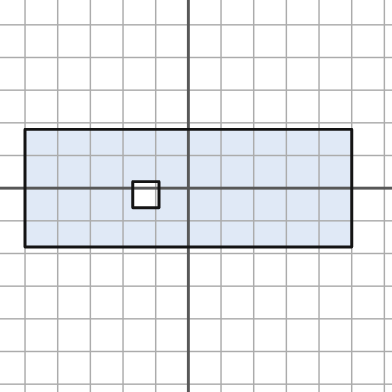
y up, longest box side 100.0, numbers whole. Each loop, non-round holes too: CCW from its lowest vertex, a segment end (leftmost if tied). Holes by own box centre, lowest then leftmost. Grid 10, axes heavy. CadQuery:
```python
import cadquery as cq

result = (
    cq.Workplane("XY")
    .moveTo(-50.0, -18.0)
    .lineTo(50.0, -18.0)
    .lineTo(50.0, 18.0)
    .lineTo(-50.0, 18.0)
    .close()
    .moveTo(-17.0, -6.0)
    .lineTo(-9.0, -6.0)
    .lineTo(-9.0, 2.0)
    .lineTo(-17.0, 2.0)
    .close()
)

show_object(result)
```